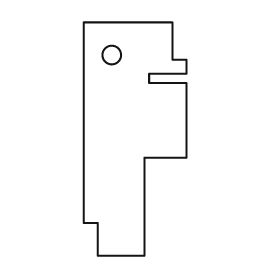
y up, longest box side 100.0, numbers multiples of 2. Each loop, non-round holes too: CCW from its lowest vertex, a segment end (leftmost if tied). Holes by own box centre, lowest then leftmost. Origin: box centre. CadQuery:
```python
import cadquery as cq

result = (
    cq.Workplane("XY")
    .moveTo(-16.0, -50.0)
    .lineTo(4.0, -50.0)
    .lineTo(4.0, -8.0)
    .lineTo(22.0, -8.0)
    .lineTo(22.0, 24.0)
    .lineTo(6.0, 24.0)
    .lineTo(6.0, 28.0)
    .lineTo(22.0, 28.0)
    .lineTo(22.0, 34.0)
    .lineTo(16.0, 34.0)
    .lineTo(16.0, 50.0)
    .lineTo(-22.0, 50.0)
    .lineTo(-22.0, -36.0)
    .lineTo(-16.0, -36.0)
    .close()
    .moveTo(-10.0, 36.0)
    .circle(4.0)
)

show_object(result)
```